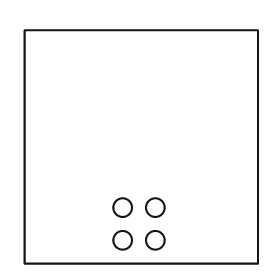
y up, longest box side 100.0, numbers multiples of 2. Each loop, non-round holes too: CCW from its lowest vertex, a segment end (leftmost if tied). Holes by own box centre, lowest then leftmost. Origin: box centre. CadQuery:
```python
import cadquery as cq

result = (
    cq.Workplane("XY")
    .moveTo(-50.0, -50.0)
    .lineTo(50.0, -50.0)
    .lineTo(50.0, 50.0)
    .lineTo(-50.0, 50.0)
    .close()
    .moveTo(-8.0, -40.0)
    .circle(4.0)
    .moveTo(6.0, -40.0)
    .circle(4.0)
    .moveTo(-8.0, -26.0)
    .circle(4.0)
    .moveTo(6.0, -26.0)
    .circle(4.0)
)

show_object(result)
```